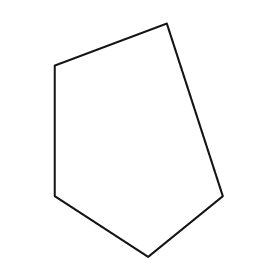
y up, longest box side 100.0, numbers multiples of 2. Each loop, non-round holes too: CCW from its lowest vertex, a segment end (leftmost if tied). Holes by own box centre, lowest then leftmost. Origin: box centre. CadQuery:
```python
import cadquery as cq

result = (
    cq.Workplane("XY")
    .moveTo(4.0, -50.0)
    .lineTo(36.0, -24.0)
    .lineTo(12.0, 50.0)
    .lineTo(-36.0, 32.0)
    .lineTo(-36.0, -24.0)
    .close()
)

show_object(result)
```